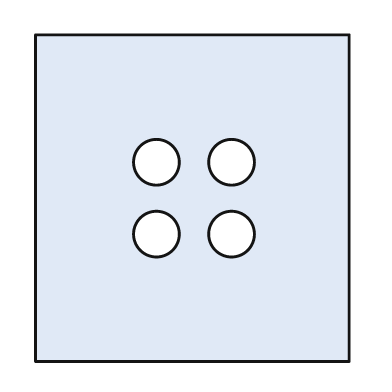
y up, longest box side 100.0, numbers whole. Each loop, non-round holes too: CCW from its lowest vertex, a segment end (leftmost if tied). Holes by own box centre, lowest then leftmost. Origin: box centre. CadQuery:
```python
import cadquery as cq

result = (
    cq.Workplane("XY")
    .moveTo(-48.0, -50.0)
    .lineTo(48.0, -50.0)
    .lineTo(48.0, 50.0)
    .lineTo(-48.0, 50.0)
    .close()
    .moveTo(-11.0, -11.0)
    .circle(7.0)
    .moveTo(12.0, -11.0)
    .circle(7.0)
    .moveTo(-11.0, 11.0)
    .circle(7.0)
    .moveTo(12.0, 11.0)
    .circle(7.0)
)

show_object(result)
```